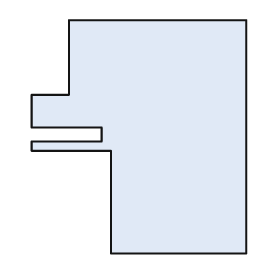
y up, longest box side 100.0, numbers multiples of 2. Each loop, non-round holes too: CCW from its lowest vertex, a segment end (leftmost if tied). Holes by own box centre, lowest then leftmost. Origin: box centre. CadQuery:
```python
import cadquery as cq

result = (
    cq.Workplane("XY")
    .moveTo(-12.0, -50.0)
    .lineTo(46.0, -50.0)
    .lineTo(46.0, 50.0)
    .lineTo(-30.0, 50.0)
    .lineTo(-30.0, 18.0)
    .lineTo(-46.0, 18.0)
    .lineTo(-46.0, 4.0)
    .lineTo(-16.0, 4.0)
    .lineTo(-16.0, -2.0)
    .lineTo(-46.0, -2.0)
    .lineTo(-46.0, -6.0)
    .lineTo(-12.0, -6.0)
    .close()
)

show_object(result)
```